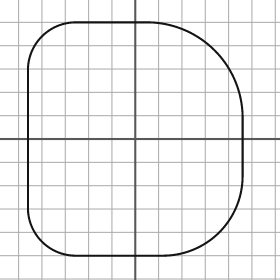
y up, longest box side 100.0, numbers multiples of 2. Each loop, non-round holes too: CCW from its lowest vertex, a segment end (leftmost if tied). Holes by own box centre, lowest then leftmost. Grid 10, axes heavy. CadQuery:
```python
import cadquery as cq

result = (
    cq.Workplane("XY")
    .moveTo(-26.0, -50.0)
    .lineTo(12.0, -50.0)
    .threePointArc((36.0, -40.0), (46.0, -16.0))
    .lineTo(46.0, 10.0)
    .threePointArc((34.0, 38.0), (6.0, 50.0))
    .lineTo(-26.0, 50.0)
    .threePointArc((-40.0, 44.0), (-46.0, 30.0))
    .lineTo(-46.0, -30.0)
    .threePointArc((-40.0, -44.0), (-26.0, -50.0))
    .close()
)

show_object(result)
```